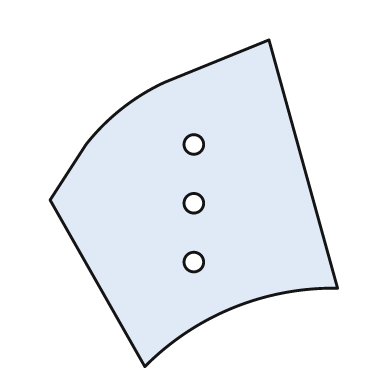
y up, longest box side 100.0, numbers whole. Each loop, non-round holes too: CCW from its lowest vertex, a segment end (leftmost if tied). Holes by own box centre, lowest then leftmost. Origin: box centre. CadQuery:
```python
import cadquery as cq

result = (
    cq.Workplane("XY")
    .moveTo(-15.0, -50.0)
    .threePointArc((12.0, -32.0), (44.0, -26.0))
    .lineTo(23.0, 50.0)
    .lineTo(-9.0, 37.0)
    .threePointArc((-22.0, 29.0), (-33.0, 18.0))
    .lineTo(-44.0, 1.0)
    .close()
    .moveTo(0.0, -18.0)
    .circle(3.0)
    .moveTo(0.0, 0.0)
    .circle(3.0)
    .moveTo(0.0, 18.0)
    .circle(3.0)
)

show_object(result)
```